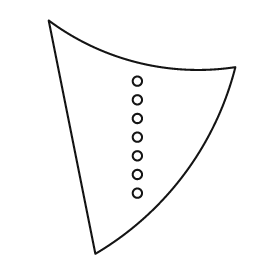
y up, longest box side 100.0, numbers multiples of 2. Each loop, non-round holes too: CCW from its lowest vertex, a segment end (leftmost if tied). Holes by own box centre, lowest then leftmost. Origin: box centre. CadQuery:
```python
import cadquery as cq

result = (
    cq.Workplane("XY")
    .moveTo(-20.0, -50.0)
    .threePointArc((18.0, -16.0), (40.0, 30.0))
    .threePointArc((-2.0, 32.0), (-40.0, 50.0))
    .close()
    .moveTo(-2.0, -24.0)
    .circle(2.0)
    .moveTo(-2.0, -16.0)
    .circle(2.0)
    .moveTo(-2.0, -8.0)
    .circle(2.0)
    .moveTo(-2.0, 0.0)
    .circle(2.0)
    .moveTo(-2.0, 8.0)
    .circle(2.0)
    .moveTo(-2.0, 16.0)
    .circle(2.0)
    .moveTo(-2.0, 24.0)
    .circle(2.0)
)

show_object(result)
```